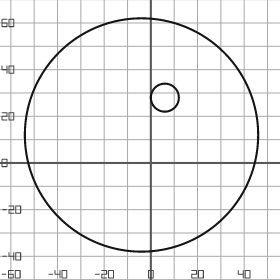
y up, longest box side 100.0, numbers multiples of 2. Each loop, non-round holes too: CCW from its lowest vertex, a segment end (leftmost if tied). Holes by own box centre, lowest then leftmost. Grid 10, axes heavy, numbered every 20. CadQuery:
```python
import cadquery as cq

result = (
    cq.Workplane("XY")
    .moveTo(-4.0, 12.0)
    .circle(50.0)
    .moveTo(6.0, 28.0)
    .circle(6.0)
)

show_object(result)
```